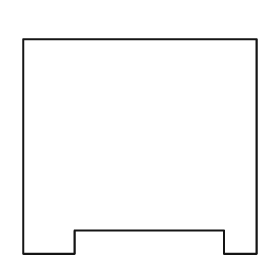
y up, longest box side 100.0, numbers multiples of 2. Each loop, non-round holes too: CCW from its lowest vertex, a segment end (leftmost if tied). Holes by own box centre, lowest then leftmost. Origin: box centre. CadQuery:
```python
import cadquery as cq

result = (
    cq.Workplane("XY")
    .moveTo(-50.0, -46.0)
    .lineTo(-28.0, -46.0)
    .lineTo(-28.0, -36.0)
    .lineTo(36.0, -36.0)
    .lineTo(36.0, -46.0)
    .lineTo(50.0, -46.0)
    .lineTo(50.0, 46.0)
    .lineTo(-50.0, 46.0)
    .close()
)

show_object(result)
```